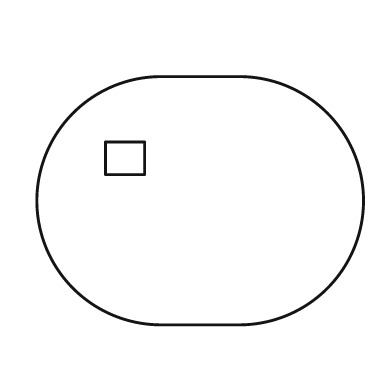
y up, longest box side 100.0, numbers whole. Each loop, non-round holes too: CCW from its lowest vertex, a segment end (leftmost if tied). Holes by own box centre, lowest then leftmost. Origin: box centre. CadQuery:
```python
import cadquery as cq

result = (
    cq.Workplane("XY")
    .moveTo(-12.0, -38.0)
    .lineTo(12.0, -38.0)
    .threePointArc((50.0, 0.0), (12.0, 38.0))
    .lineTo(-12.0, 38.0)
    .threePointArc((-50.0, 0.0), (-12.0, -38.0))
    .close()
    .moveTo(-29.0, 8.0)
    .lineTo(-17.0, 8.0)
    .lineTo(-17.0, 18.0)
    .lineTo(-29.0, 18.0)
    .close()
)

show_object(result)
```